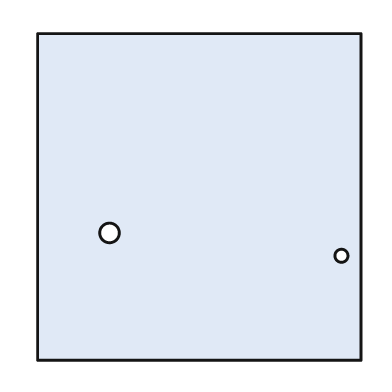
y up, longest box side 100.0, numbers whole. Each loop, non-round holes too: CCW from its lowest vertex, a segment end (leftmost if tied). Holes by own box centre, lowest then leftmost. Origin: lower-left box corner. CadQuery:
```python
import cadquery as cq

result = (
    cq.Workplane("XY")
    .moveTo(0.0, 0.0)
    .lineTo(99.0, 0.0)
    .lineTo(99.0, 100.0)
    .lineTo(0.0, 100.0)
    .close()
    .moveTo(93.0, 32.0)
    .circle(2.0)
    .moveTo(22.0, 39.0)
    .circle(3.0)
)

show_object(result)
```